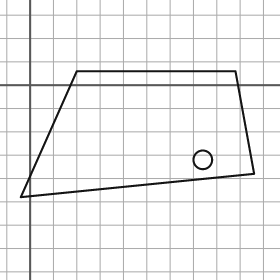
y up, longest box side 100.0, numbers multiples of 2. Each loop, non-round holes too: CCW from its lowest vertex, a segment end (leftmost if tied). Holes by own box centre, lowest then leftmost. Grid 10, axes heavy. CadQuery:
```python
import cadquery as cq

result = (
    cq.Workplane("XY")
    .moveTo(-4.0, -48.0)
    .lineTo(96.0, -38.0)
    .lineTo(88.0, 6.0)
    .lineTo(20.0, 6.0)
    .close()
    .moveTo(74.0, -32.0)
    .circle(4.0)
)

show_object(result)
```